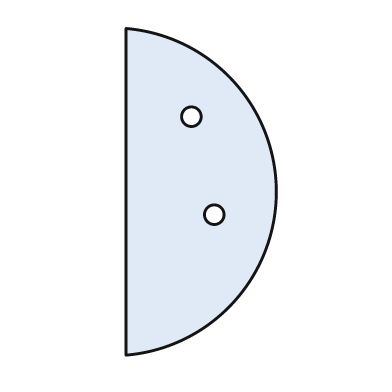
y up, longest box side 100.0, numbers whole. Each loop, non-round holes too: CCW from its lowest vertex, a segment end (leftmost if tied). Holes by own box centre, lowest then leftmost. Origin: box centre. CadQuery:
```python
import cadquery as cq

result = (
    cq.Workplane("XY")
    .moveTo(-23.0, -50.0)
    .threePointArc((23.0, 0.0), (-23.0, 50.0))
    .close()
    .moveTo(4.0, -7.0)
    .circle(3.0)
    .moveTo(-3.0, 23.0)
    .circle(3.0)
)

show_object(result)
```